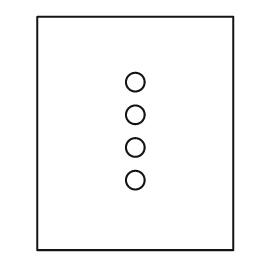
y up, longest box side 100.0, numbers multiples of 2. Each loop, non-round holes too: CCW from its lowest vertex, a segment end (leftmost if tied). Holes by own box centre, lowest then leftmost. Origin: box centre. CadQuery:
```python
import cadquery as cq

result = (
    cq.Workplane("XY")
    .moveTo(-42.0, -50.0)
    .lineTo(42.0, -50.0)
    .lineTo(42.0, 50.0)
    .lineTo(-42.0, 50.0)
    .close()
    .moveTo(0.0, -20.0)
    .circle(4.0)
    .moveTo(0.0, -6.0)
    .circle(4.0)
    .moveTo(0.0, 8.0)
    .circle(4.0)
    .moveTo(0.0, 22.0)
    .circle(4.0)
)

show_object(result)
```